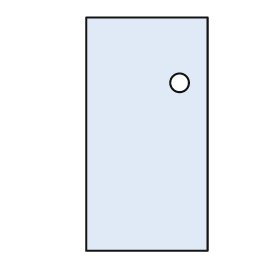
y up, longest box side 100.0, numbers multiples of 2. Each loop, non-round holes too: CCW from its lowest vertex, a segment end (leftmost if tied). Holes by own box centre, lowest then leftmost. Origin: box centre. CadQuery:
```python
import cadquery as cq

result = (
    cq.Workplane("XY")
    .moveTo(-26.0, -50.0)
    .lineTo(26.0, -50.0)
    .lineTo(26.0, 50.0)
    .lineTo(-26.0, 50.0)
    .close()
    .moveTo(14.0, 22.0)
    .circle(4.0)
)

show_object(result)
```